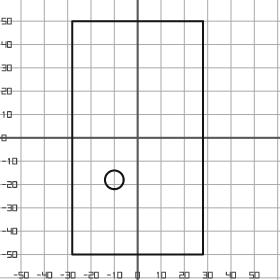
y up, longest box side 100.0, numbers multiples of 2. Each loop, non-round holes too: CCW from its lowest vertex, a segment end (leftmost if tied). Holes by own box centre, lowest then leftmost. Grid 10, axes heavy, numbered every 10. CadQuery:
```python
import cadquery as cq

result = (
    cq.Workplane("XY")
    .moveTo(-28.0, -50.0)
    .lineTo(28.0, -50.0)
    .lineTo(28.0, 50.0)
    .lineTo(-28.0, 50.0)
    .close()
    .moveTo(-10.0, -18.0)
    .circle(4.0)
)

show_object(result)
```